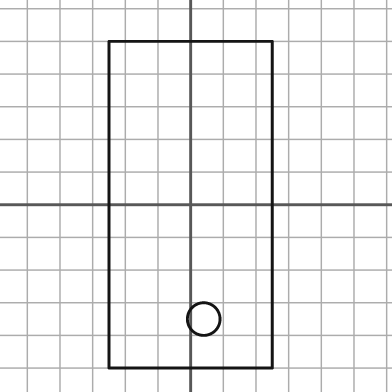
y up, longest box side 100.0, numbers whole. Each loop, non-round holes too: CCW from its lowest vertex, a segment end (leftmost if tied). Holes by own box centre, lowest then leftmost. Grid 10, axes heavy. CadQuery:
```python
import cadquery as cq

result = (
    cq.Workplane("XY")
    .moveTo(-25.0, -50.0)
    .lineTo(25.0, -50.0)
    .lineTo(25.0, 50.0)
    .lineTo(-25.0, 50.0)
    .close()
    .moveTo(4.0, -35.0)
    .circle(5.0)
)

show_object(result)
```